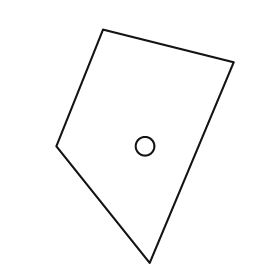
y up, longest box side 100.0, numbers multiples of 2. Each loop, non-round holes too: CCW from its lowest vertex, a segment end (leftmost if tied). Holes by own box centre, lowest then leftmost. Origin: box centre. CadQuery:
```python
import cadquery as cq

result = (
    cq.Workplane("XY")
    .moveTo(2.0, -50.0)
    .lineTo(38.0, 36.0)
    .lineTo(-18.0, 50.0)
    .lineTo(-38.0, 0.0)
    .close()
    .moveTo(0.0, 0.0)
    .circle(4.0)
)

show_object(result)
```